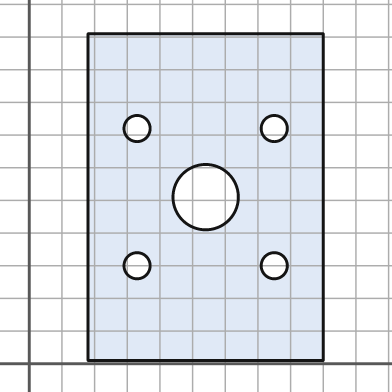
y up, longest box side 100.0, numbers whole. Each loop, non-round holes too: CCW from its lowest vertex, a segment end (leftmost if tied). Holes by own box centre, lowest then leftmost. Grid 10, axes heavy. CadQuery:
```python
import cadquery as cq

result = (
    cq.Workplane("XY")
    .moveTo(18.0, 1.0)
    .lineTo(90.0, 1.0)
    .lineTo(90.0, 101.0)
    .lineTo(18.0, 101.0)
    .close()
    .moveTo(33.0, 30.0)
    .circle(4.0)
    .moveTo(75.0, 30.0)
    .circle(4.0)
    .moveTo(54.0, 51.0)
    .circle(10.0)
    .moveTo(33.0, 72.0)
    .circle(4.0)
    .moveTo(75.0, 72.0)
    .circle(4.0)
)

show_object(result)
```